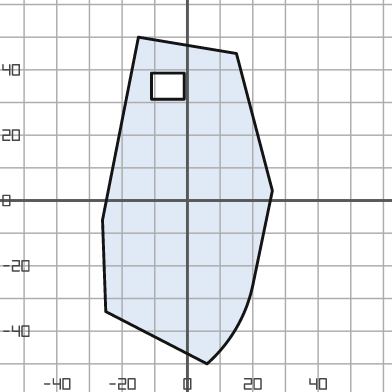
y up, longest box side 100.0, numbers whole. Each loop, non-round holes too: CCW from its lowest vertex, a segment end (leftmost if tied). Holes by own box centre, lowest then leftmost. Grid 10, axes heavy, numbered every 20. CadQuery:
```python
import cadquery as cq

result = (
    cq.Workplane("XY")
    .moveTo(6.0, -50.0)
    .threePointArc((15.0, -39.0), (20.0, -26.0))
    .lineTo(26.0, 3.0)
    .lineTo(15.0, 45.0)
    .lineTo(-15.0, 50.0)
    .lineTo(-26.0, -6.0)
    .lineTo(-25.0, -34.0)
    .close()
    .moveTo(-11.0, 31.0)
    .lineTo(-1.0, 31.0)
    .lineTo(-1.0, 39.0)
    .lineTo(-11.0, 39.0)
    .close()
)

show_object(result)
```